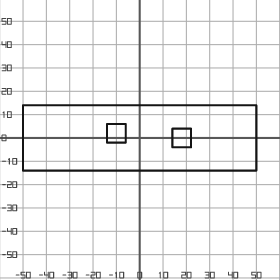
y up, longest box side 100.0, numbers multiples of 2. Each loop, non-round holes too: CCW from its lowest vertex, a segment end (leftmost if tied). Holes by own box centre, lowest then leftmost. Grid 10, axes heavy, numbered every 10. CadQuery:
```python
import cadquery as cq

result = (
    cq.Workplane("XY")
    .moveTo(-50.0, -14.0)
    .lineTo(50.0, -14.0)
    .lineTo(50.0, 14.0)
    .lineTo(-50.0, 14.0)
    .close()
    .moveTo(14.0, -4.0)
    .lineTo(22.0, -4.0)
    .lineTo(22.0, 4.0)
    .lineTo(14.0, 4.0)
    .close()
    .moveTo(-14.0, -2.0)
    .lineTo(-6.0, -2.0)
    .lineTo(-6.0, 6.0)
    .lineTo(-14.0, 6.0)
    .close()
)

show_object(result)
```